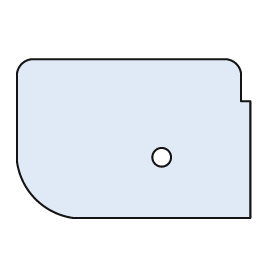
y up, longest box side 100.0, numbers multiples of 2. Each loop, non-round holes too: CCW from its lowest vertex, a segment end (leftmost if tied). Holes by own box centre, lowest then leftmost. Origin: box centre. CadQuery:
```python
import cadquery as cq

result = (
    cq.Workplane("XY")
    .moveTo(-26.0, -34.0)
    .lineTo(50.0, -34.0)
    .lineTo(50.0, 16.0)
    .lineTo(46.0, 16.0)
    .lineTo(46.0, 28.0)
    .threePointArc((44.0, 32.0), (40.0, 34.0))
    .lineTo(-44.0, 34.0)
    .threePointArc((-48.0, 32.0), (-50.0, 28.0))
    .lineTo(-50.0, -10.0)
    .threePointArc((-42.0, -26.0), (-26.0, -34.0))
    .close()
    .moveTo(12.0, -8.0)
    .circle(4.0)
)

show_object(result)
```